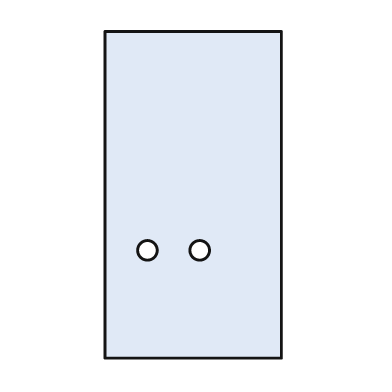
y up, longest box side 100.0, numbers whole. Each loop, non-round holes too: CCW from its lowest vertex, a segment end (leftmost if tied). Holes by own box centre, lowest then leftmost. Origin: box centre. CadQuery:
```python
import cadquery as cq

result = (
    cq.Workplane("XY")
    .moveTo(-27.0, -50.0)
    .lineTo(27.0, -50.0)
    .lineTo(27.0, 50.0)
    .lineTo(-27.0, 50.0)
    .close()
    .moveTo(-14.0, -17.0)
    .circle(3.0)
    .moveTo(2.0, -17.0)
    .circle(3.0)
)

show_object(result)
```